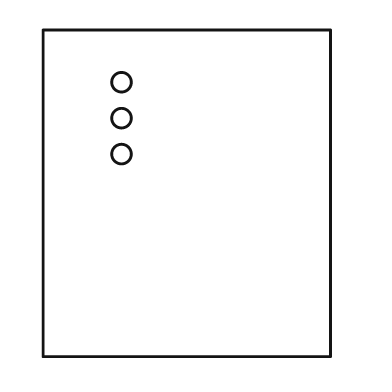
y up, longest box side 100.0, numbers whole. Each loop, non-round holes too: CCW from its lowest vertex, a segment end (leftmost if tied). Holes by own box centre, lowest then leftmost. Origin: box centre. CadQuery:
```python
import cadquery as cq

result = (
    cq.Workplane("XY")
    .moveTo(-44.0, -50.0)
    .lineTo(44.0, -50.0)
    .lineTo(44.0, 50.0)
    .lineTo(-44.0, 50.0)
    .close()
    .moveTo(-20.0, 12.0)
    .circle(3.0)
    .moveTo(-20.0, 23.0)
    .circle(3.0)
    .moveTo(-20.0, 34.0)
    .circle(3.0)
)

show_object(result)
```